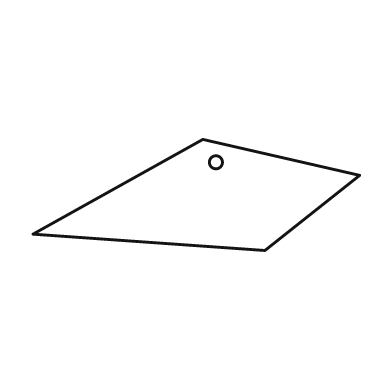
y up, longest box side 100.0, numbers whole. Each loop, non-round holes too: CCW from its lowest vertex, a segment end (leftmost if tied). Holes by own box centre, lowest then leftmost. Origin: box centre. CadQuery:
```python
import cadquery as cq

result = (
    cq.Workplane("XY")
    .moveTo(21.0, -17.0)
    .lineTo(50.0, 6.0)
    .lineTo(2.0, 17.0)
    .lineTo(-50.0, -12.0)
    .close()
    .moveTo(6.0, 10.0)
    .circle(2.0)
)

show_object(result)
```